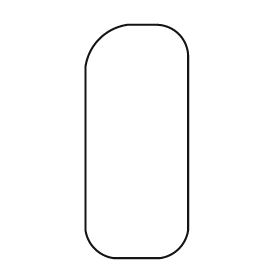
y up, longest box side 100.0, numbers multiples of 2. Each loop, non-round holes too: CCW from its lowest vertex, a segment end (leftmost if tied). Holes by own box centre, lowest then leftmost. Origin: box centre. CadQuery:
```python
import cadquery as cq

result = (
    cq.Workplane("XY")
    .moveTo(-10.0, -50.0)
    .lineTo(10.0, -50.0)
    .threePointArc((18.0, -46.0), (22.0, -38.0))
    .lineTo(22.0, 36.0)
    .threePointArc((18.0, 46.0), (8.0, 50.0))
    .lineTo(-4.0, 50.0)
    .threePointArc((-16.0, 44.0), (-22.0, 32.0))
    .lineTo(-22.0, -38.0)
    .threePointArc((-18.0, -46.0), (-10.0, -50.0))
    .close()
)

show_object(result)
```